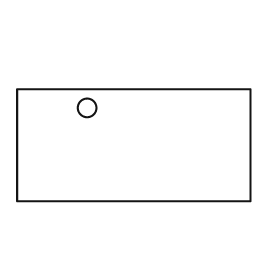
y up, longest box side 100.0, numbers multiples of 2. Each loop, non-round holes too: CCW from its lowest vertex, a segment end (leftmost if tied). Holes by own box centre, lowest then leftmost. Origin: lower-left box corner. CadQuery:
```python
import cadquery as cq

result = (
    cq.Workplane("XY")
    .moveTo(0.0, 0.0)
    .lineTo(100.0, 0.0)
    .lineTo(100.0, 48.0)
    .lineTo(0.0, 48.0)
    .close()
    .moveTo(30.0, 40.0)
    .circle(4.0)
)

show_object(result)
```